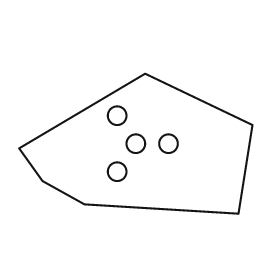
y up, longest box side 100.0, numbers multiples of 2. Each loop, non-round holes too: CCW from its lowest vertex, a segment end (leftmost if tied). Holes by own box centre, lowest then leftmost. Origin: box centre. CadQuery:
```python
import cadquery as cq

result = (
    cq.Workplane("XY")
    .moveTo(44.0, -30.0)
    .lineTo(50.0, 8.0)
    .lineTo(4.0, 30.0)
    .lineTo(-50.0, -2.0)
    .lineTo(-40.0, -16.0)
    .lineTo(-22.0, -26.0)
    .close()
    .moveTo(-8.0, -12.0)
    .circle(4.0)
    .moveTo(0.0, 0.0)
    .circle(4.0)
    .moveTo(14.0, 0.0)
    .circle(4.0)
    .moveTo(-8.0, 12.0)
    .circle(4.0)
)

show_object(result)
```